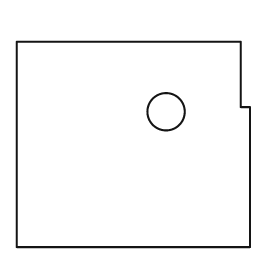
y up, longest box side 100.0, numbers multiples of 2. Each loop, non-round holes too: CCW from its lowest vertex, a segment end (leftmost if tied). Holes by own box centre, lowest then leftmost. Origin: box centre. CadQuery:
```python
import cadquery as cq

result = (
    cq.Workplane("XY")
    .moveTo(-50.0, -44.0)
    .lineTo(50.0, -44.0)
    .lineTo(50.0, 16.0)
    .lineTo(46.0, 16.0)
    .lineTo(46.0, 44.0)
    .lineTo(-50.0, 44.0)
    .close()
    .moveTo(14.0, 14.0)
    .circle(8.0)
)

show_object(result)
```